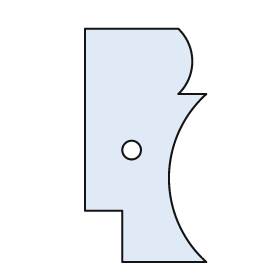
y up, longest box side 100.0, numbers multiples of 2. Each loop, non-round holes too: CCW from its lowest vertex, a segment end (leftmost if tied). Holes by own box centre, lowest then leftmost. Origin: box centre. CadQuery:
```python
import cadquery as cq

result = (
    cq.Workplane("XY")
    .moveTo(-10.0, -50.0)
    .lineTo(26.0, -50.0)
    .threePointArc((10.0, -14.0), (26.0, 22.0))
    .lineTo(14.0, 22.0)
    .threePointArc((20.0, 36.0), (14.0, 50.0))
    .lineTo(-26.0, 50.0)
    .lineTo(-26.0, -28.0)
    .lineTo(-10.0, -28.0)
    .close()
    .moveTo(-6.0, -2.0)
    .circle(4.0)
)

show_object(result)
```